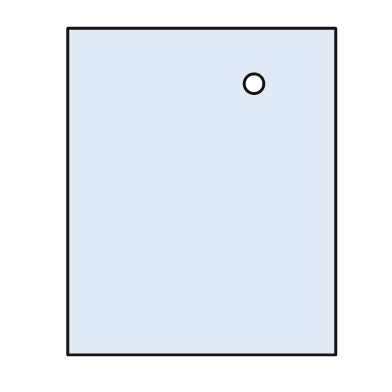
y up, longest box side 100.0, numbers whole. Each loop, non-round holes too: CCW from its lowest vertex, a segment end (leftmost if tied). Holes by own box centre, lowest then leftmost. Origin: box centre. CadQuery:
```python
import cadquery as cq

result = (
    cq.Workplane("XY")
    .moveTo(-41.0, -50.0)
    .lineTo(41.0, -50.0)
    .lineTo(41.0, 50.0)
    .lineTo(-41.0, 50.0)
    .close()
    .moveTo(16.0, 33.0)
    .circle(3.0)
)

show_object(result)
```